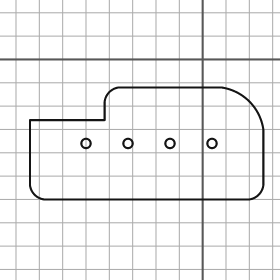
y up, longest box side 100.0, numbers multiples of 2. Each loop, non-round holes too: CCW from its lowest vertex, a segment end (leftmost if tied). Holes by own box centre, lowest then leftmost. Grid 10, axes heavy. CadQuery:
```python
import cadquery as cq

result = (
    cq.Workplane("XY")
    .moveTo(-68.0, -60.0)
    .lineTo(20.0, -60.0)
    .threePointArc((24.0, -58.0), (26.0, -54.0))
    .lineTo(26.0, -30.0)
    .threePointArc((20.0, -18.0), (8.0, -12.0))
    .lineTo(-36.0, -12.0)
    .threePointArc((-40.0, -14.0), (-42.0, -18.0))
    .lineTo(-42.0, -26.0)
    .lineTo(-74.0, -26.0)
    .lineTo(-74.0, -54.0)
    .threePointArc((-72.0, -58.0), (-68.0, -60.0))
    .close()
    .moveTo(-50.0, -36.0)
    .circle(2.0)
    .moveTo(-32.0, -36.0)
    .circle(2.0)
    .moveTo(-14.0, -36.0)
    .circle(2.0)
    .moveTo(4.0, -36.0)
    .circle(2.0)
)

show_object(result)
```